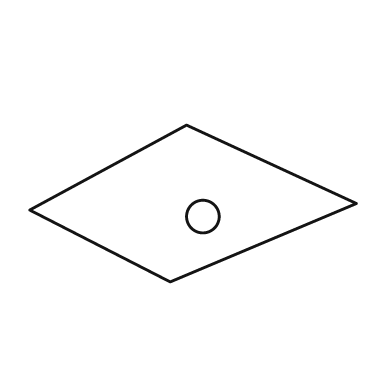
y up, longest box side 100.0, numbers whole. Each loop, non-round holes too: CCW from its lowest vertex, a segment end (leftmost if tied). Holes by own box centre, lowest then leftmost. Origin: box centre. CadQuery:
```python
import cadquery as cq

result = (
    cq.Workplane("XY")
    .moveTo(-7.0, -24.0)
    .lineTo(50.0, 0.0)
    .lineTo(-2.0, 24.0)
    .lineTo(-50.0, -2.0)
    .close()
    .moveTo(3.0, -4.0)
    .circle(5.0)
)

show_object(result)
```